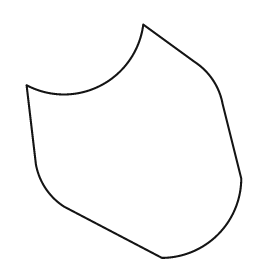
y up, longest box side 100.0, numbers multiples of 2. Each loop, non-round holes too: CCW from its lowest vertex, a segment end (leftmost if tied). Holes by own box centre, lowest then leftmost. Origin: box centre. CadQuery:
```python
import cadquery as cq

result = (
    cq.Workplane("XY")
    .moveTo(12.0, -50.0)
    .threePointArc((36.0, -40.0), (46.0, -16.0))
    .lineTo(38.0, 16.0)
    .threePointArc((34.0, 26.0), (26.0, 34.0))
    .lineTo(4.0, 50.0)
    .threePointArc((-14.0, 24.0), (-46.0, 24.0))
    .lineTo(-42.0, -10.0)
    .threePointArc((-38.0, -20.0), (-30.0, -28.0))
    .close()
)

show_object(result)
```